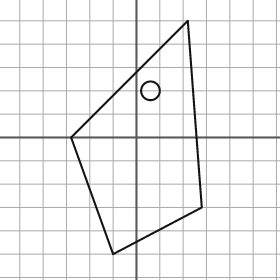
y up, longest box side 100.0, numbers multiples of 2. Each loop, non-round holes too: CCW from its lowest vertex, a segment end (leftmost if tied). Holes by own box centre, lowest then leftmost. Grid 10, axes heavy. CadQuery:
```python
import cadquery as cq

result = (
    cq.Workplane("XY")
    .moveTo(-10.0, -50.0)
    .lineTo(28.0, -30.0)
    .lineTo(22.0, 50.0)
    .lineTo(-28.0, 0.0)
    .close()
    .moveTo(6.0, 20.0)
    .circle(4.0)
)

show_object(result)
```